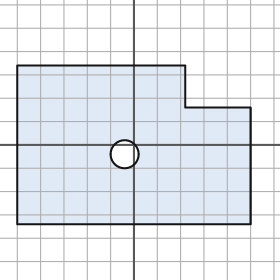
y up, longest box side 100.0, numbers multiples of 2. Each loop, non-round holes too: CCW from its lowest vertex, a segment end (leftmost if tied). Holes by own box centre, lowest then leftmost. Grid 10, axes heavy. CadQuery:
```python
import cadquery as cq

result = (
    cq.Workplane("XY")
    .moveTo(-50.0, -34.0)
    .lineTo(50.0, -34.0)
    .lineTo(50.0, 16.0)
    .lineTo(22.0, 16.0)
    .lineTo(22.0, 34.0)
    .lineTo(-50.0, 34.0)
    .close()
    .moveTo(-4.0, -4.0)
    .circle(6.0)
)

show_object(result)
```